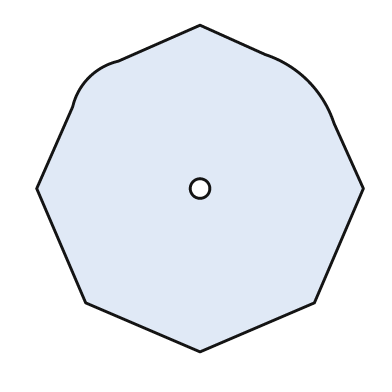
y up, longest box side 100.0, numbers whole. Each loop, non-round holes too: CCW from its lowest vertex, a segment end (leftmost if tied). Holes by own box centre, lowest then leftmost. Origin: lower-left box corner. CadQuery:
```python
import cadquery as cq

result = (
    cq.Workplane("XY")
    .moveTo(50.0, 0.0)
    .lineTo(85.0, 15.0)
    .lineTo(100.0, 50.0)
    .lineTo(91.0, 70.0)
    .threePointArc((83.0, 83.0), (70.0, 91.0))
    .lineTo(50.0, 100.0)
    .lineTo(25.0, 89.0)
    .threePointArc((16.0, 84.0), (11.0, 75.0))
    .lineTo(0.0, 50.0)
    .lineTo(15.0, 15.0)
    .close()
    .moveTo(50.0, 50.0)
    .circle(3.0)
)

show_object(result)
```